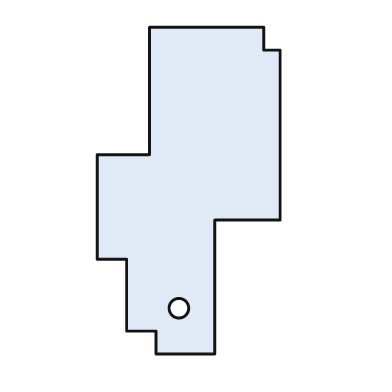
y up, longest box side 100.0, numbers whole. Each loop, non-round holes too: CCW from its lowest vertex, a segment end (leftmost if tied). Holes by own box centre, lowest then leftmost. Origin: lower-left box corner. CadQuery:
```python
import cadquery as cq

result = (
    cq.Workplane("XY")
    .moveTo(18.0, 0.0)
    .lineTo(36.0, 0.0)
    .lineTo(36.0, 41.0)
    .lineTo(56.0, 41.0)
    .lineTo(56.0, 93.0)
    .lineTo(51.0, 93.0)
    .lineTo(51.0, 100.0)
    .lineTo(16.0, 100.0)
    .lineTo(16.0, 61.0)
    .lineTo(0.0, 61.0)
    .lineTo(0.0, 29.0)
    .lineTo(9.0, 29.0)
    .lineTo(9.0, 7.0)
    .lineTo(18.0, 7.0)
    .close()
    .moveTo(25.0, 14.0)
    .circle(3.0)
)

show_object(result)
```